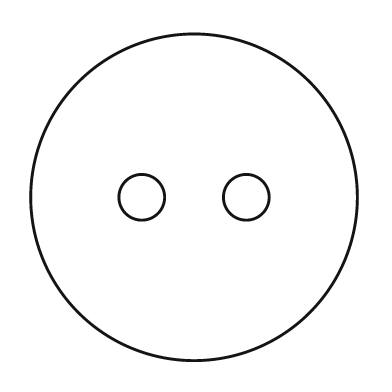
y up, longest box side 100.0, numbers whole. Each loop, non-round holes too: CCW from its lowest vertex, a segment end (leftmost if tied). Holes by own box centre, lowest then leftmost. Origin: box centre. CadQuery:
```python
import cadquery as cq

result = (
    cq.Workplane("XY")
    .moveTo(0.0, 0.0)
    .circle(50.0)
    .moveTo(-16.0, 0.0)
    .circle(7.0)
    .moveTo(16.0, 0.0)
    .circle(7.0)
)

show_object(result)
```